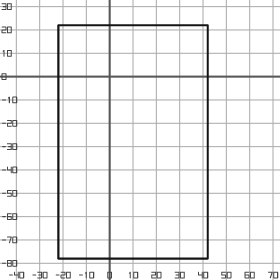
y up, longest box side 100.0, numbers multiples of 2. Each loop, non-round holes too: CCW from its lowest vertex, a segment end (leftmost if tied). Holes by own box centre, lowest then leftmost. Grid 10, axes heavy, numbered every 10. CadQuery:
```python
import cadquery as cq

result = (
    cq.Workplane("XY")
    .moveTo(-22.0, -78.0)
    .lineTo(42.0, -78.0)
    .lineTo(42.0, 22.0)
    .lineTo(-22.0, 22.0)
    .close()
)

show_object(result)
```